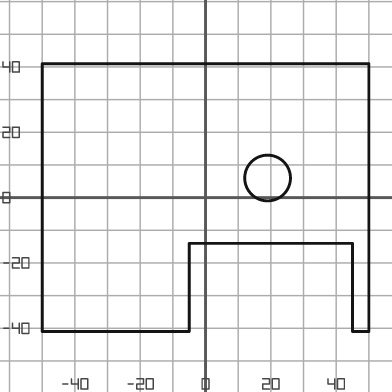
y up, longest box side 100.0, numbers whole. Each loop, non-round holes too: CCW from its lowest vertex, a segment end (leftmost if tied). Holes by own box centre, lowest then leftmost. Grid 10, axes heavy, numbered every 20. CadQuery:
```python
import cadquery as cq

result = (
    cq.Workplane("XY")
    .moveTo(-50.0, -41.0)
    .lineTo(-5.0, -41.0)
    .lineTo(-5.0, -14.0)
    .lineTo(45.0, -14.0)
    .lineTo(45.0, -41.0)
    .lineTo(50.0, -41.0)
    .lineTo(50.0, 41.0)
    .lineTo(-50.0, 41.0)
    .close()
    .moveTo(19.0, 6.0)
    .circle(7.0)
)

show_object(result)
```